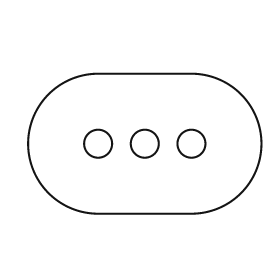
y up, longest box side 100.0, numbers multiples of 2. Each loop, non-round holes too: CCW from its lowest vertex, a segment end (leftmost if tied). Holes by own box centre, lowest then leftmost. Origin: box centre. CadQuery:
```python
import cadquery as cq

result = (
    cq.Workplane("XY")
    .moveTo(-20.0, -30.0)
    .lineTo(20.0, -30.0)
    .threePointArc((50.0, 0.0), (20.0, 30.0))
    .lineTo(-20.0, 30.0)
    .threePointArc((-50.0, 0.0), (-20.0, -30.0))
    .close()
    .moveTo(-20.0, 0.0)
    .circle(6.0)
    .moveTo(0.0, 0.0)
    .circle(6.0)
    .moveTo(20.0, 0.0)
    .circle(6.0)
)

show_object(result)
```